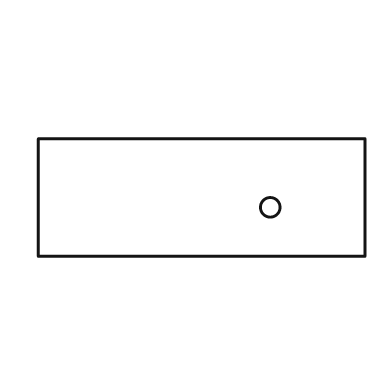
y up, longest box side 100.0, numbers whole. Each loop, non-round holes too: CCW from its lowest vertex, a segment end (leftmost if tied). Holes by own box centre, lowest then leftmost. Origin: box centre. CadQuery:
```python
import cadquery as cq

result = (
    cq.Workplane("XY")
    .moveTo(-50.0, -18.0)
    .lineTo(50.0, -18.0)
    .lineTo(50.0, 18.0)
    .lineTo(-50.0, 18.0)
    .close()
    .moveTo(21.0, -3.0)
    .circle(3.0)
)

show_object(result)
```